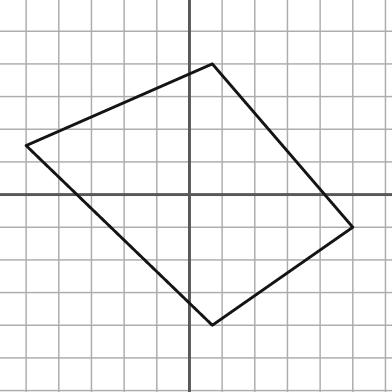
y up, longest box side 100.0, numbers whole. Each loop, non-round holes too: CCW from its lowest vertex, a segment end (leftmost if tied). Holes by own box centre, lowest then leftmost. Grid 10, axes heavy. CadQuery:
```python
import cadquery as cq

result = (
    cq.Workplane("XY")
    .moveTo(7.0, -40.0)
    .lineTo(50.0, -10.0)
    .lineTo(7.0, 40.0)
    .lineTo(-50.0, 15.0)
    .close()
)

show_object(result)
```